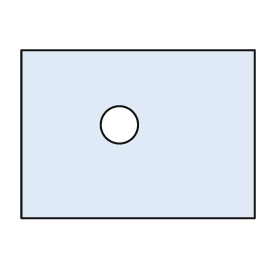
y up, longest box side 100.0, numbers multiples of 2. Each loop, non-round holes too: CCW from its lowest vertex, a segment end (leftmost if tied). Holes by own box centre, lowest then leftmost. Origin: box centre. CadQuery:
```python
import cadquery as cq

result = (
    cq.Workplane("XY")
    .moveTo(-50.0, -36.0)
    .lineTo(50.0, -36.0)
    .lineTo(50.0, 36.0)
    .lineTo(-50.0, 36.0)
    .close()
    .moveTo(-8.0, 4.0)
    .circle(8.0)
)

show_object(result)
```